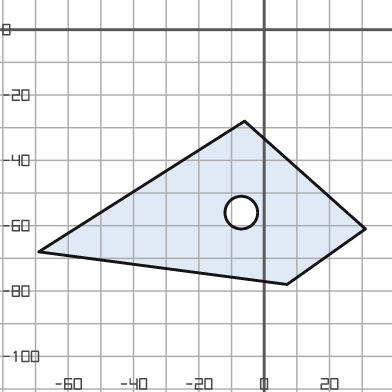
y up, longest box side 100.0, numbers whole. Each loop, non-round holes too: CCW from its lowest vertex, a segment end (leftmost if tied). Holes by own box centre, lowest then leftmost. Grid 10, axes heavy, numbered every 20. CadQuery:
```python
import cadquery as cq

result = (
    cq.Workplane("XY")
    .moveTo(7.0, -78.0)
    .lineTo(31.0, -61.0)
    .lineTo(-6.0, -28.0)
    .lineTo(-69.0, -68.0)
    .close()
    .moveTo(-7.0, -56.0)
    .circle(5.0)
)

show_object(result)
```